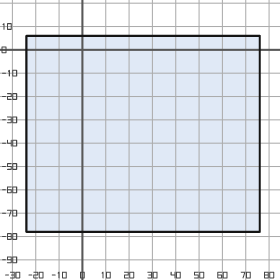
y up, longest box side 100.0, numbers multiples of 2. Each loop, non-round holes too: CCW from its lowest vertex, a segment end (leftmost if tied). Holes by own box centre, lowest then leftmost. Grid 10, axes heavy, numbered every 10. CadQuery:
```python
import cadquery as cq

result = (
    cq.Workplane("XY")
    .moveTo(-24.0, -78.0)
    .lineTo(76.0, -78.0)
    .lineTo(76.0, 6.0)
    .lineTo(-24.0, 6.0)
    .close()
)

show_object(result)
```